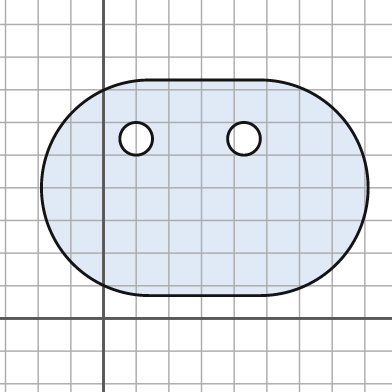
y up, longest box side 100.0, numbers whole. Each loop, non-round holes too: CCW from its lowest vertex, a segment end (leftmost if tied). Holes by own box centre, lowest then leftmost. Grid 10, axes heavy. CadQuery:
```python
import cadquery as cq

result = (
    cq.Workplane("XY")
    .moveTo(14.0, 7.0)
    .lineTo(48.0, 7.0)
    .threePointArc((81.0, 40.0), (48.0, 73.0))
    .lineTo(14.0, 73.0)
    .threePointArc((-19.0, 40.0), (14.0, 7.0))
    .close()
    .moveTo(10.0, 55.0)
    .circle(5.0)
    .moveTo(43.0, 55.0)
    .circle(5.0)
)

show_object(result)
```